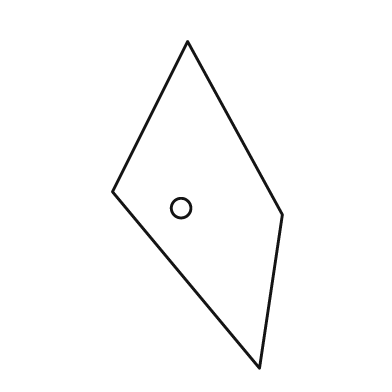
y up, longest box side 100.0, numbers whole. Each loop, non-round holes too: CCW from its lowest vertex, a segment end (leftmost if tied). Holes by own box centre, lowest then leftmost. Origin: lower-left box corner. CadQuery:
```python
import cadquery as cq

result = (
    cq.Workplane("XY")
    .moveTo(45.0, 0.0)
    .lineTo(52.0, 47.0)
    .lineTo(23.0, 100.0)
    .lineTo(0.0, 54.0)
    .close()
    .moveTo(21.0, 49.0)
    .circle(3.0)
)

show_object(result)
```